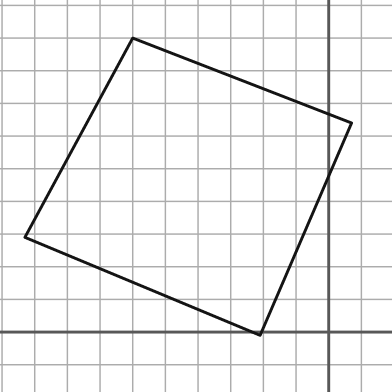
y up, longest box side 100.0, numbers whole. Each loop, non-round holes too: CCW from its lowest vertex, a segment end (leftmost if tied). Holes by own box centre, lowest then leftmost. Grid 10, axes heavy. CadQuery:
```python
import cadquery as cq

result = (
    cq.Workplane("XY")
    .moveTo(-21.0, -1.0)
    .lineTo(7.0, 64.0)
    .lineTo(-60.0, 90.0)
    .lineTo(-93.0, 29.0)
    .close()
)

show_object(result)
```